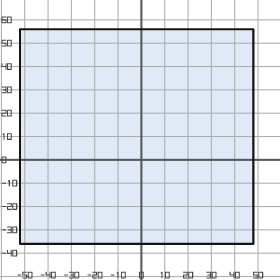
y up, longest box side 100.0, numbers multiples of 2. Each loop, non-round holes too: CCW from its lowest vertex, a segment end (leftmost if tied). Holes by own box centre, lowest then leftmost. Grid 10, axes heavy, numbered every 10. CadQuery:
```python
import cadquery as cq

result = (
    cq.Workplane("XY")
    .moveTo(-52.0, -36.0)
    .lineTo(48.0, -36.0)
    .lineTo(48.0, 56.0)
    .lineTo(-52.0, 56.0)
    .close()
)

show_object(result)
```